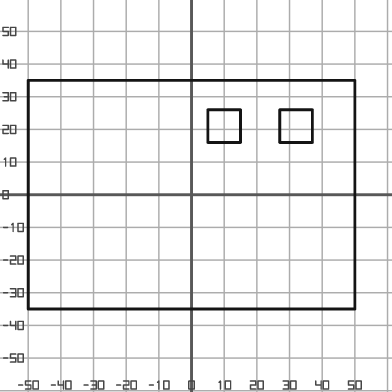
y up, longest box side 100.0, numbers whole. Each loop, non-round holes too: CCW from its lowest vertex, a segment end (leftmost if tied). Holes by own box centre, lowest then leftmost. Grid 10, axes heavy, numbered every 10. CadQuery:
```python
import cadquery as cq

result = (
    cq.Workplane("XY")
    .moveTo(-50.0, -35.0)
    .lineTo(50.0, -35.0)
    .lineTo(50.0, 35.0)
    .lineTo(-50.0, 35.0)
    .close()
    .moveTo(5.0, 16.0)
    .lineTo(15.0, 16.0)
    .lineTo(15.0, 26.0)
    .lineTo(5.0, 26.0)
    .close()
    .moveTo(27.0, 16.0)
    .lineTo(37.0, 16.0)
    .lineTo(37.0, 26.0)
    .lineTo(27.0, 26.0)
    .close()
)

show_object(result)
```